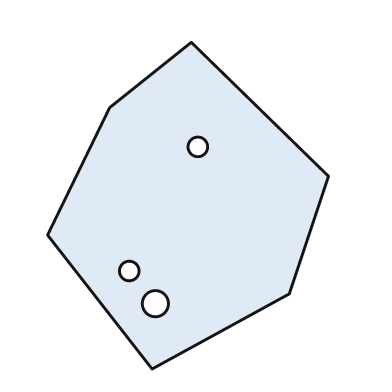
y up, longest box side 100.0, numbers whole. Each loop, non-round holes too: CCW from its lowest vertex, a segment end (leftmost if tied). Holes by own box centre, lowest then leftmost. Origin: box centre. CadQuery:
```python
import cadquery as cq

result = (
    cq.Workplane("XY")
    .moveTo(-11.0, -50.0)
    .lineTo(31.0, -27.0)
    .lineTo(43.0, 9.0)
    .lineTo(1.0, 50.0)
    .lineTo(-24.0, 30.0)
    .lineTo(-43.0, -9.0)
    .close()
    .moveTo(-10.0, -30.0)
    .circle(4.0)
    .moveTo(-18.0, -20.0)
    .circle(3.0)
    .moveTo(3.0, 18.0)
    .circle(3.0)
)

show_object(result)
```